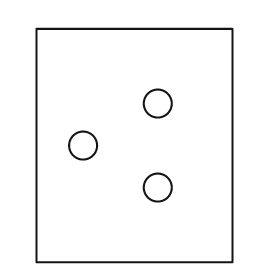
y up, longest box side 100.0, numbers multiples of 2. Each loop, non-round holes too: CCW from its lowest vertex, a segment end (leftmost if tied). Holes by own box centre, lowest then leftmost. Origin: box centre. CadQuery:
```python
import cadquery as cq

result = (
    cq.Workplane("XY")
    .moveTo(-42.0, -50.0)
    .lineTo(42.0, -50.0)
    .lineTo(42.0, 50.0)
    .lineTo(-42.0, 50.0)
    .close()
    .moveTo(10.0, -18.0)
    .circle(6.0)
    .moveTo(-22.0, 0.0)
    .circle(6.0)
    .moveTo(10.0, 18.0)
    .circle(6.0)
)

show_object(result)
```